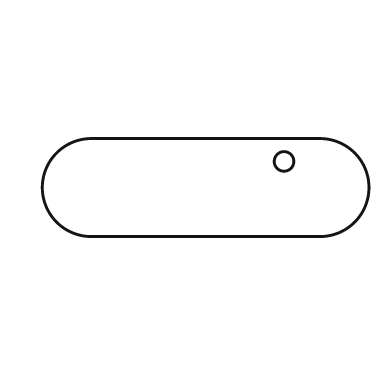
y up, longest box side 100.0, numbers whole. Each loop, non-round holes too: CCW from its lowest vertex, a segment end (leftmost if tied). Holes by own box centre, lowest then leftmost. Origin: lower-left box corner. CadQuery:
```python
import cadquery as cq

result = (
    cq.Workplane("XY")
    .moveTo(15.0, 0.0)
    .lineTo(85.0, 0.0)
    .threePointArc((100.0, 15.0), (85.0, 30.0))
    .lineTo(15.0, 30.0)
    .threePointArc((0.0, 15.0), (15.0, 0.0))
    .close()
    .moveTo(74.0, 23.0)
    .circle(3.0)
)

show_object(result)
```